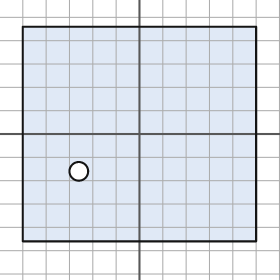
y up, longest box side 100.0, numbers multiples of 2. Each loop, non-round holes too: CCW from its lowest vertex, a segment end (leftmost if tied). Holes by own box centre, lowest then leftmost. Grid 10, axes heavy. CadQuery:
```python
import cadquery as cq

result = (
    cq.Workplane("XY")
    .moveTo(-50.0, -46.0)
    .lineTo(50.0, -46.0)
    .lineTo(50.0, 46.0)
    .lineTo(-50.0, 46.0)
    .close()
    .moveTo(-26.0, -16.0)
    .circle(4.0)
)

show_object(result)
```